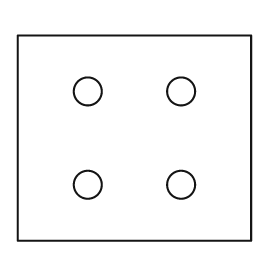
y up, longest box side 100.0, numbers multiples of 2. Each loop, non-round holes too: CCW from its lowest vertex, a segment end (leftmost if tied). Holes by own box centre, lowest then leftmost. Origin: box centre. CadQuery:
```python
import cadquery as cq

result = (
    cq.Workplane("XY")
    .moveTo(-50.0, -44.0)
    .lineTo(50.0, -44.0)
    .lineTo(50.0, 44.0)
    .lineTo(-50.0, 44.0)
    .close()
    .moveTo(-20.0, -20.0)
    .circle(6.0)
    .moveTo(20.0, -20.0)
    .circle(6.0)
    .moveTo(-20.0, 20.0)
    .circle(6.0)
    .moveTo(20.0, 20.0)
    .circle(6.0)
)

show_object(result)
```